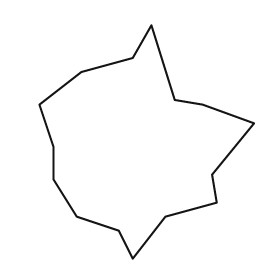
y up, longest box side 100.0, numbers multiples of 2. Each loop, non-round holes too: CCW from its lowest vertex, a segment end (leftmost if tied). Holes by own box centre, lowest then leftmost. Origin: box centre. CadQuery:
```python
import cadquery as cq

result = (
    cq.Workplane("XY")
    .moveTo(-6.0, -50.0)
    .lineTo(8.0, -32.0)
    .lineTo(30.0, -26.0)
    .lineTo(28.0, -14.0)
    .lineTo(46.0, 8.0)
    .lineTo(24.0, 16.0)
    .lineTo(12.0, 18.0)
    .lineTo(2.0, 50.0)
    .lineTo(-6.0, 36.0)
    .lineTo(-28.0, 30.0)
    .lineTo(-46.0, 16.0)
    .lineTo(-40.0, -2.0)
    .lineTo(-40.0, -16.0)
    .lineTo(-30.0, -32.0)
    .lineTo(-12.0, -38.0)
    .close()
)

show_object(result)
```